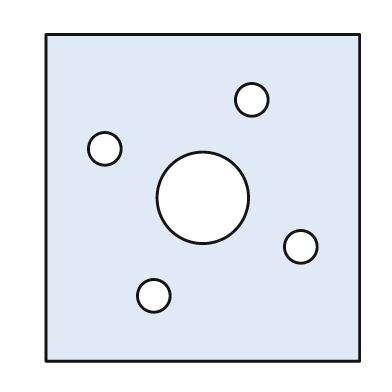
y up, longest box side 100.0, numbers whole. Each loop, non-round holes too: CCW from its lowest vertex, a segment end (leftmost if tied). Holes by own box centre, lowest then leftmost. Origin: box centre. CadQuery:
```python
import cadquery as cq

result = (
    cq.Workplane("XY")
    .moveTo(-48.0, -50.0)
    .lineTo(48.0, -50.0)
    .lineTo(48.0, 50.0)
    .lineTo(-48.0, 50.0)
    .close()
    .moveTo(-15.0, -30.0)
    .circle(5.0)
    .moveTo(30.0, -15.0)
    .circle(5.0)
    .moveTo(0.0, 0.0)
    .circle(14.0)
    .moveTo(-30.0, 15.0)
    .circle(5.0)
    .moveTo(15.0, 30.0)
    .circle(5.0)
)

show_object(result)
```